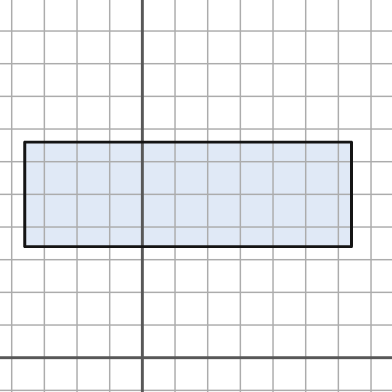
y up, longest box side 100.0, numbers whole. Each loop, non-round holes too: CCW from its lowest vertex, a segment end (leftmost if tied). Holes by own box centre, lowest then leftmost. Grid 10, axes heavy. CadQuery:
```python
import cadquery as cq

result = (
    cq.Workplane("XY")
    .moveTo(-36.0, 34.0)
    .lineTo(64.0, 34.0)
    .lineTo(64.0, 66.0)
    .lineTo(-36.0, 66.0)
    .close()
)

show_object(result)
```